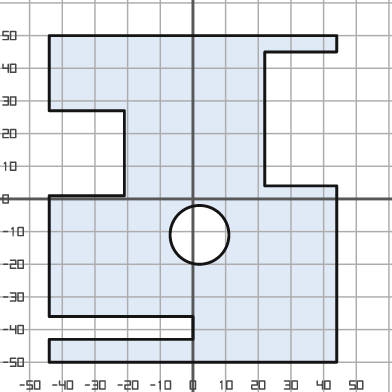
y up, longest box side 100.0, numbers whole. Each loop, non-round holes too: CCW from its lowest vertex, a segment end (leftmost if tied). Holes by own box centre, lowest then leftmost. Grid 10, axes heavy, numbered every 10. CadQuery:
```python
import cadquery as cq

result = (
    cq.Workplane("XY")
    .moveTo(-44.0, -50.0)
    .lineTo(44.0, -50.0)
    .lineTo(44.0, 4.0)
    .lineTo(22.0, 4.0)
    .lineTo(22.0, 45.0)
    .lineTo(44.0, 45.0)
    .lineTo(44.0, 50.0)
    .lineTo(-44.0, 50.0)
    .lineTo(-44.0, 27.0)
    .lineTo(-21.0, 27.0)
    .lineTo(-21.0, 1.0)
    .lineTo(-44.0, 1.0)
    .lineTo(-44.0, -36.0)
    .lineTo(0.0, -36.0)
    .lineTo(0.0, -43.0)
    .lineTo(-44.0, -43.0)
    .close()
    .moveTo(2.0, -11.0)
    .circle(9.0)
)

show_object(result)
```